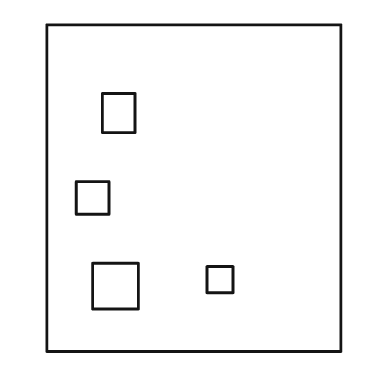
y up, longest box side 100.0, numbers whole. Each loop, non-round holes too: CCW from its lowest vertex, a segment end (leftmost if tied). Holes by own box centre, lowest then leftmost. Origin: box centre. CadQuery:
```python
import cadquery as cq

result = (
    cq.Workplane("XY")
    .moveTo(-45.0, -50.0)
    .lineTo(45.0, -50.0)
    .lineTo(45.0, 50.0)
    .lineTo(-45.0, 50.0)
    .close()
    .moveTo(-31.0, -37.0)
    .lineTo(-17.0, -37.0)
    .lineTo(-17.0, -23.0)
    .lineTo(-31.0, -23.0)
    .close()
    .moveTo(4.0, -32.0)
    .lineTo(12.0, -32.0)
    .lineTo(12.0, -24.0)
    .lineTo(4.0, -24.0)
    .close()
    .moveTo(-36.0, -8.0)
    .lineTo(-26.0, -8.0)
    .lineTo(-26.0, 2.0)
    .lineTo(-36.0, 2.0)
    .close()
    .moveTo(-28.0, 17.0)
    .lineTo(-18.0, 17.0)
    .lineTo(-18.0, 29.0)
    .lineTo(-28.0, 29.0)
    .close()
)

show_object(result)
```